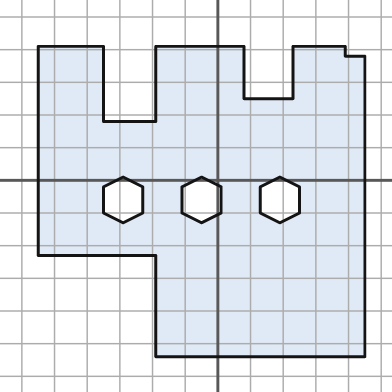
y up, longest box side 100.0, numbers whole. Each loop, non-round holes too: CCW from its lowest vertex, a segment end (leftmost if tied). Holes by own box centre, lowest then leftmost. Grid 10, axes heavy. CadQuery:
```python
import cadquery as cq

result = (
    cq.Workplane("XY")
    .moveTo(-19.0, -54.0)
    .lineTo(45.0, -54.0)
    .lineTo(45.0, 38.0)
    .lineTo(39.0, 38.0)
    .lineTo(39.0, 41.0)
    .lineTo(23.0, 41.0)
    .lineTo(23.0, 25.0)
    .lineTo(8.0, 25.0)
    .lineTo(8.0, 41.0)
    .lineTo(-19.0, 41.0)
    .lineTo(-19.0, 18.0)
    .lineTo(-35.0, 18.0)
    .lineTo(-35.0, 41.0)
    .lineTo(-55.0, 41.0)
    .lineTo(-55.0, -23.0)
    .lineTo(-19.0, -23.0)
    .close()
    .moveTo(-29.0, -13.0)
    .lineTo(-23.0, -10.0)
    .lineTo(-23.0, -2.0)
    .lineTo(-29.0, 1.0)
    .lineTo(-35.0, -2.0)
    .lineTo(-35.0, -10.0)
    .close()
    .moveTo(-5.0, -13.0)
    .lineTo(1.0, -10.0)
    .lineTo(1.0, -2.0)
    .lineTo(-5.0, 1.0)
    .lineTo(-11.0, -2.0)
    .lineTo(-11.0, -10.0)
    .close()
    .moveTo(19.0, -13.0)
    .lineTo(25.0, -10.0)
    .lineTo(25.0, -2.0)
    .lineTo(19.0, 1.0)
    .lineTo(13.0, -2.0)
    .lineTo(13.0, -10.0)
    .close()
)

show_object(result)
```